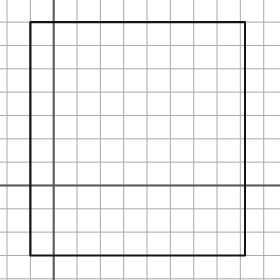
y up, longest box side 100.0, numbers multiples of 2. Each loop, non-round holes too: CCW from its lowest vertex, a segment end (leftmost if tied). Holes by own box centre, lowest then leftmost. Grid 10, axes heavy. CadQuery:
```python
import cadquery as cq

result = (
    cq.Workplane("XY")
    .moveTo(-10.0, -30.0)
    .lineTo(82.0, -30.0)
    .lineTo(82.0, 70.0)
    .lineTo(-10.0, 70.0)
    .close()
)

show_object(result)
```